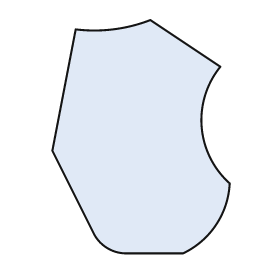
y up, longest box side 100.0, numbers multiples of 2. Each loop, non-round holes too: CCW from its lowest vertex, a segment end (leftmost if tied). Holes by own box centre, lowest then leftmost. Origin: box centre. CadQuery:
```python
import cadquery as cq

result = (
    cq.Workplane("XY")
    .moveTo(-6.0, -50.0)
    .lineTo(18.0, -50.0)
    .threePointArc((32.0, -38.0), (38.0, -20.0))
    .threePointArc((26.0, 4.0), (34.0, 30.0))
    .lineTo(4.0, 50.0)
    .threePointArc((-12.0, 46.0), (-28.0, 46.0))
    .lineTo(-38.0, -6.0)
    .lineTo(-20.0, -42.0)
    .threePointArc((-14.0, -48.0), (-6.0, -50.0))
    .close()
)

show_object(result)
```